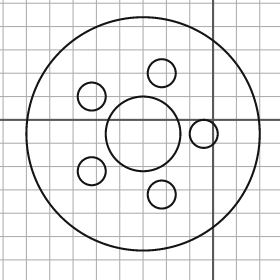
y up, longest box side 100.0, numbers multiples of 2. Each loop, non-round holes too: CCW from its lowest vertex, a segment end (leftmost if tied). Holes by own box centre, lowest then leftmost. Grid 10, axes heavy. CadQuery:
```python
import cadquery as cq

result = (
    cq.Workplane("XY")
    .moveTo(-30.0, -6.0)
    .circle(50.0)
    .moveTo(-22.0, -32.0)
    .circle(6.0)
    .moveTo(-52.0, -22.0)
    .circle(6.0)
    .moveTo(-30.0, -6.0)
    .circle(16.0)
    .moveTo(-4.0, -6.0)
    .circle(6.0)
    .moveTo(-52.0, 10.0)
    .circle(6.0)
    .moveTo(-22.0, 20.0)
    .circle(6.0)
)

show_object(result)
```